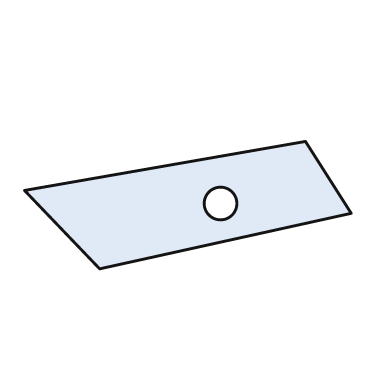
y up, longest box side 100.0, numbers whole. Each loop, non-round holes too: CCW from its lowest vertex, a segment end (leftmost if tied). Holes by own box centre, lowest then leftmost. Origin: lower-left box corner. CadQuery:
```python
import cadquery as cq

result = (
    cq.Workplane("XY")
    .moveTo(23.0, 0.0)
    .lineTo(100.0, 17.0)
    .lineTo(86.0, 39.0)
    .lineTo(0.0, 24.0)
    .close()
    .moveTo(60.0, 20.0)
    .circle(5.0)
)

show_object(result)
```